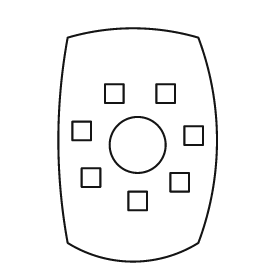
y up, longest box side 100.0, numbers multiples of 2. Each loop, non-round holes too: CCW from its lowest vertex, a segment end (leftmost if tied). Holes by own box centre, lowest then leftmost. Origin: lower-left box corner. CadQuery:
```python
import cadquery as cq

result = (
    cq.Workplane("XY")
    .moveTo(4.0, 8.0)
    .threePointArc((32.0, 0.0), (60.0, 8.0))
    .threePointArc((68.0, 52.0), (60.0, 96.0))
    .threePointArc((32.0, 100.0), (4.0, 96.0))
    .threePointArc((0.0, 52.0), (4.0, 8.0))
    .close()
    .moveTo(30.0, 22.0)
    .lineTo(38.0, 22.0)
    .lineTo(38.0, 30.0)
    .lineTo(30.0, 30.0)
    .close()
    .moveTo(48.0, 30.0)
    .lineTo(56.0, 30.0)
    .lineTo(56.0, 38.0)
    .lineTo(48.0, 38.0)
    .close()
    .moveTo(10.0, 32.0)
    .lineTo(18.0, 32.0)
    .lineTo(18.0, 40.0)
    .lineTo(10.0, 40.0)
    .close()
    .moveTo(34.0, 50.0)
    .circle(12.0)
    .moveTo(54.0, 50.0)
    .lineTo(62.0, 50.0)
    .lineTo(62.0, 58.0)
    .lineTo(54.0, 58.0)
    .close()
    .moveTo(6.0, 52.0)
    .lineTo(14.0, 52.0)
    .lineTo(14.0, 60.0)
    .lineTo(6.0, 60.0)
    .close()
    .moveTo(20.0, 68.0)
    .lineTo(28.0, 68.0)
    .lineTo(28.0, 76.0)
    .lineTo(20.0, 76.0)
    .close()
    .moveTo(42.0, 68.0)
    .lineTo(50.0, 68.0)
    .lineTo(50.0, 76.0)
    .lineTo(42.0, 76.0)
    .close()
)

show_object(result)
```